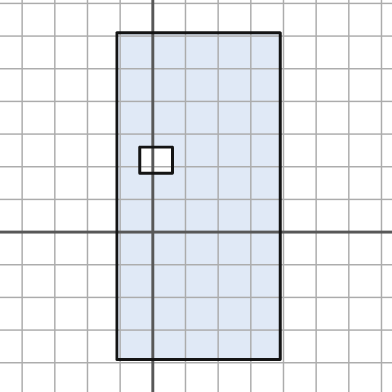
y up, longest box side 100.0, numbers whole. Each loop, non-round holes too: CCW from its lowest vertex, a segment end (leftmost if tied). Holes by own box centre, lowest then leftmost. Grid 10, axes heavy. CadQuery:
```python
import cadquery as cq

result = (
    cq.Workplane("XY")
    .moveTo(-11.0, -39.0)
    .lineTo(39.0, -39.0)
    .lineTo(39.0, 61.0)
    .lineTo(-11.0, 61.0)
    .close()
    .moveTo(-4.0, 18.0)
    .lineTo(6.0, 18.0)
    .lineTo(6.0, 26.0)
    .lineTo(-4.0, 26.0)
    .close()
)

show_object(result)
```